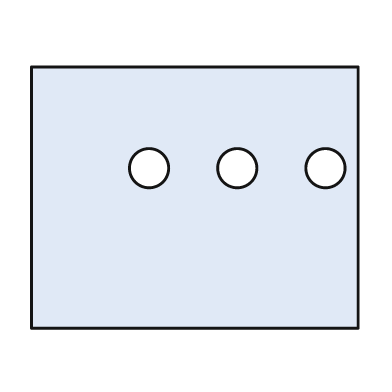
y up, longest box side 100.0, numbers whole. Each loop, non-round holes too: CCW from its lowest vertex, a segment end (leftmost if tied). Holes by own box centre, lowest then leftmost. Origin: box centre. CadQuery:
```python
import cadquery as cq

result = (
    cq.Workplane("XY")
    .moveTo(-50.0, -40.0)
    .lineTo(50.0, -40.0)
    .lineTo(50.0, 40.0)
    .lineTo(-50.0, 40.0)
    .close()
    .moveTo(-14.0, 9.0)
    .circle(6.0)
    .moveTo(13.0, 9.0)
    .circle(6.0)
    .moveTo(40.0, 9.0)
    .circle(6.0)
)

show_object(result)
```